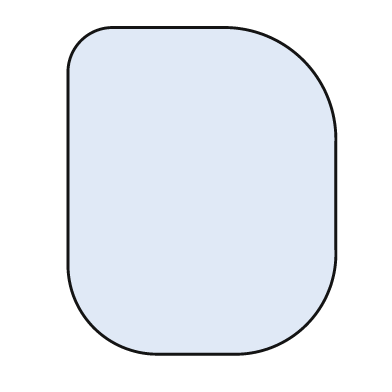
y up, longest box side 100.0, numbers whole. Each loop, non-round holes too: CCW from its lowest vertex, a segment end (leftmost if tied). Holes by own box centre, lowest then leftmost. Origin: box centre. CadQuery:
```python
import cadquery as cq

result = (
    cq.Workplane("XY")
    .moveTo(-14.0, -50.0)
    .lineTo(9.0, -50.0)
    .threePointArc((32.0, -41.0), (41.0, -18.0))
    .lineTo(41.0, 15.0)
    .threePointArc((31.0, 40.0), (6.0, 50.0))
    .lineTo(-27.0, 50.0)
    .threePointArc((-37.0, 46.0), (-41.0, 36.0))
    .lineTo(-41.0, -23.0)
    .threePointArc((-33.0, -42.0), (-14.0, -50.0))
    .close()
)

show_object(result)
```